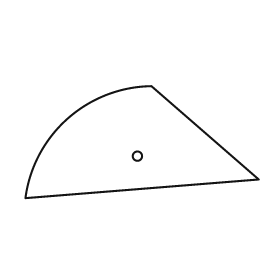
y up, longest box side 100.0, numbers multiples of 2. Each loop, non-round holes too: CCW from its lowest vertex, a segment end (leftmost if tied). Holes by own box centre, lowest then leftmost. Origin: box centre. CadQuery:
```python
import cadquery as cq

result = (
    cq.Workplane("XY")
    .moveTo(-50.0, -24.0)
    .lineTo(50.0, -16.0)
    .lineTo(4.0, 24.0)
    .threePointArc((-32.0, 10.0), (-50.0, -24.0))
    .close()
    .moveTo(-2.0, -6.0)
    .circle(2.0)
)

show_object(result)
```